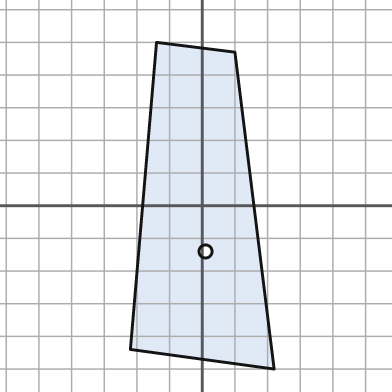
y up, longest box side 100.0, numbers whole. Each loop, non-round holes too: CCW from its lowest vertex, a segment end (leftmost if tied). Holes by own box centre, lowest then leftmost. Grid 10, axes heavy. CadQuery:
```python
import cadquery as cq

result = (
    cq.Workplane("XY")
    .moveTo(22.0, -50.0)
    .lineTo(10.0, 47.0)
    .lineTo(-14.0, 50.0)
    .lineTo(-22.0, -44.0)
    .close()
    .moveTo(1.0, -14.0)
    .circle(2.0)
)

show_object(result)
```